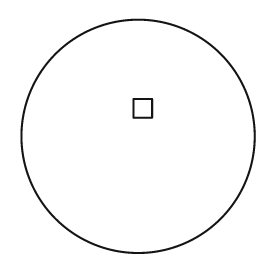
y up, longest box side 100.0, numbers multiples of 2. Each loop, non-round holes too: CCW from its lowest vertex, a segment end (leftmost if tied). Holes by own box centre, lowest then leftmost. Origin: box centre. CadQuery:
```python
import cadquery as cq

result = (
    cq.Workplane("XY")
    .moveTo(0.0, 0.0)
    .circle(50.0)
    .moveTo(-2.0, 8.0)
    .lineTo(6.0, 8.0)
    .lineTo(6.0, 16.0)
    .lineTo(-2.0, 16.0)
    .close()
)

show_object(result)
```